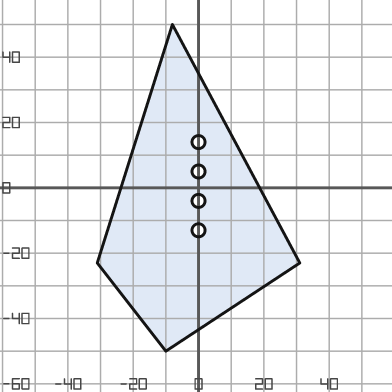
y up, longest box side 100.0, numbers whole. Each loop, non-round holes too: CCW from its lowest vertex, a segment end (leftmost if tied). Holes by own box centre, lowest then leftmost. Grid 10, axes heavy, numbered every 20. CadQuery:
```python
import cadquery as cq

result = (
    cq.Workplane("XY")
    .moveTo(-10.0, -50.0)
    .lineTo(31.0, -23.0)
    .lineTo(-8.0, 50.0)
    .lineTo(-31.0, -23.0)
    .close()
    .moveTo(0.0, -13.0)
    .circle(2.0)
    .moveTo(0.0, -4.0)
    .circle(2.0)
    .moveTo(0.0, 5.0)
    .circle(2.0)
    .moveTo(0.0, 14.0)
    .circle(2.0)
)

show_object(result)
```